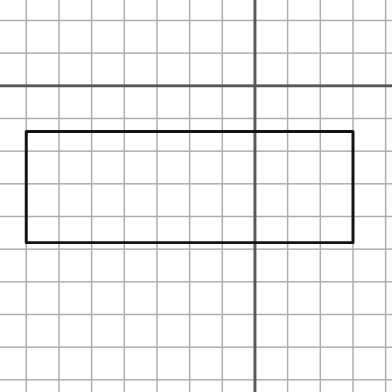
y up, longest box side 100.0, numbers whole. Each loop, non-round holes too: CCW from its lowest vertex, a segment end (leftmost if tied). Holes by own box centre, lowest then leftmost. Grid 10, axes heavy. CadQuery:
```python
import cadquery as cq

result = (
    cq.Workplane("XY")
    .moveTo(-70.0, -48.0)
    .lineTo(30.0, -48.0)
    .lineTo(30.0, -14.0)
    .lineTo(-70.0, -14.0)
    .close()
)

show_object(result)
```